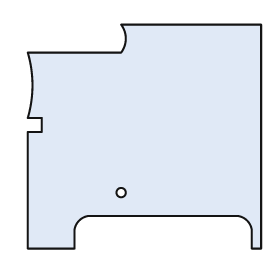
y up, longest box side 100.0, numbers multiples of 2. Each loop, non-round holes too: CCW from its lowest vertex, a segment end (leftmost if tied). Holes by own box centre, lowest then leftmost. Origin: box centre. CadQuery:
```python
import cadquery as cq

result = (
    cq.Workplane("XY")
    .moveTo(-50.0, -48.0)
    .lineTo(-30.0, -48.0)
    .lineTo(-30.0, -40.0)
    .threePointArc((-28.0, -36.0), (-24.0, -34.0))
    .lineTo(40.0, -34.0)
    .threePointArc((44.0, -36.0), (46.0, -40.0))
    .lineTo(46.0, -48.0)
    .lineTo(50.0, -48.0)
    .lineTo(50.0, 48.0)
    .lineTo(-10.0, 48.0)
    .threePointArc((-8.0, 42.0), (-10.0, 36.0))
    .lineTo(-50.0, 36.0)
    .threePointArc((-48.0, 22.0), (-50.0, 8.0))
    .lineTo(-44.0, 8.0)
    .lineTo(-44.0, 2.0)
    .lineTo(-50.0, 2.0)
    .close()
    .moveTo(-10.0, -24.0)
    .circle(2.0)
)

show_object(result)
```